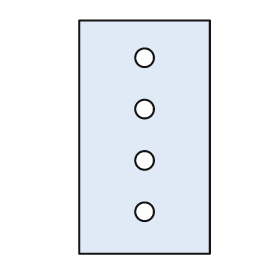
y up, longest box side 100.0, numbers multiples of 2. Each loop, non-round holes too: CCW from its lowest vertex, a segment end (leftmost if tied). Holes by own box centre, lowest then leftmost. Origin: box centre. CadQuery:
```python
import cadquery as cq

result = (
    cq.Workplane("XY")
    .moveTo(-28.0, -50.0)
    .lineTo(28.0, -50.0)
    .lineTo(28.0, 50.0)
    .lineTo(-28.0, 50.0)
    .close()
    .moveTo(0.0, -32.0)
    .circle(4.0)
    .moveTo(0.0, -10.0)
    .circle(4.0)
    .moveTo(0.0, 12.0)
    .circle(4.0)
    .moveTo(0.0, 34.0)
    .circle(4.0)
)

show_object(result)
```